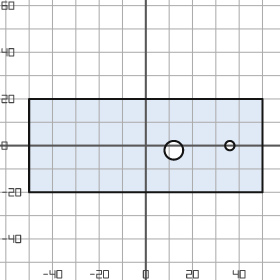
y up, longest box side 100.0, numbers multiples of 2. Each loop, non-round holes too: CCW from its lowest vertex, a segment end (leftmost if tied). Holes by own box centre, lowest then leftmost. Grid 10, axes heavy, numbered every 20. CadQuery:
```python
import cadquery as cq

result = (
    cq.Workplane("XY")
    .moveTo(-50.0, -20.0)
    .lineTo(50.0, -20.0)
    .lineTo(50.0, 20.0)
    .lineTo(-50.0, 20.0)
    .close()
    .moveTo(12.0, -2.0)
    .circle(4.0)
    .moveTo(36.0, 0.0)
    .circle(2.0)
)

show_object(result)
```